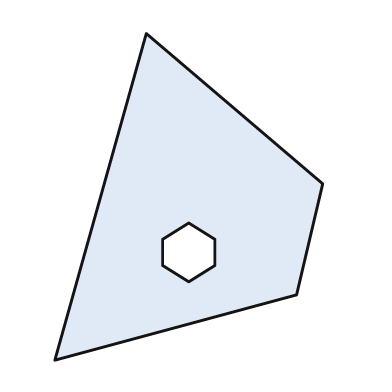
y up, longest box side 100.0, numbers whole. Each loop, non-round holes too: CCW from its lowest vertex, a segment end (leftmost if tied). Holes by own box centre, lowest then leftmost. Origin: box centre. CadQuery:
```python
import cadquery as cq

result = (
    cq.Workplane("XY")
    .moveTo(-41.0, -50.0)
    .lineTo(33.0, -30.0)
    .lineTo(41.0, 4.0)
    .lineTo(-13.0, 50.0)
    .close()
    .moveTo(0.0, -26.0)
    .lineTo(8.0, -21.0)
    .lineTo(8.0, -13.0)
    .lineTo(0.0, -8.0)
    .lineTo(-8.0, -13.0)
    .lineTo(-8.0, -21.0)
    .close()
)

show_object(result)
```